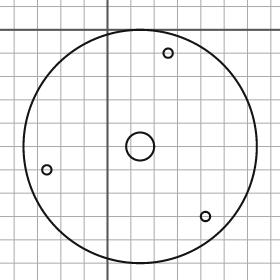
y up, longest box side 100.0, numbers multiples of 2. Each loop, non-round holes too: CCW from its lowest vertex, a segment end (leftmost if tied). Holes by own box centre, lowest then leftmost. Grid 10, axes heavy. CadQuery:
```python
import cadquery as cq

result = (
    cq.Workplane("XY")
    .moveTo(14.0, -50.0)
    .circle(50.0)
    .moveTo(42.0, -80.0)
    .circle(2.0)
    .moveTo(-26.0, -60.0)
    .circle(2.0)
    .moveTo(14.0, -50.0)
    .circle(6.0)
    .moveTo(26.0, -10.0)
    .circle(2.0)
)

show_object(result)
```